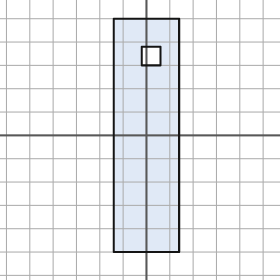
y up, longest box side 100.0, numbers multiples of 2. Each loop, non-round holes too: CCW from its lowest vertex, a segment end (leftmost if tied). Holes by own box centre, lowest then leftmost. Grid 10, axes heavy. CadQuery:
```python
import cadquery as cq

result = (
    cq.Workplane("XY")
    .moveTo(-14.0, -50.0)
    .lineTo(14.0, -50.0)
    .lineTo(14.0, 50.0)
    .lineTo(-14.0, 50.0)
    .close()
    .moveTo(-2.0, 30.0)
    .lineTo(6.0, 30.0)
    .lineTo(6.0, 38.0)
    .lineTo(-2.0, 38.0)
    .close()
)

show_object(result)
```